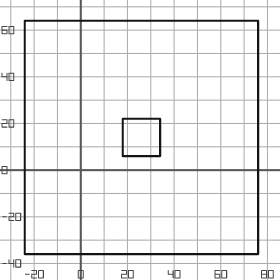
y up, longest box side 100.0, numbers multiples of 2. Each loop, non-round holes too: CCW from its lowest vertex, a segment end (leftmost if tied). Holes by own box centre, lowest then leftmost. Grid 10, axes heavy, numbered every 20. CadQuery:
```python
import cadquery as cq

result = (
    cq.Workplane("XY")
    .moveTo(-24.0, -36.0)
    .lineTo(76.0, -36.0)
    .lineTo(76.0, 64.0)
    .lineTo(-24.0, 64.0)
    .close()
    .moveTo(18.0, 6.0)
    .lineTo(34.0, 6.0)
    .lineTo(34.0, 22.0)
    .lineTo(18.0, 22.0)
    .close()
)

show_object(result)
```